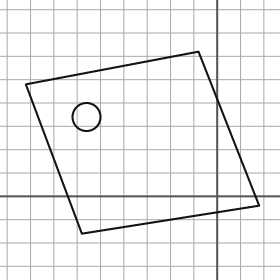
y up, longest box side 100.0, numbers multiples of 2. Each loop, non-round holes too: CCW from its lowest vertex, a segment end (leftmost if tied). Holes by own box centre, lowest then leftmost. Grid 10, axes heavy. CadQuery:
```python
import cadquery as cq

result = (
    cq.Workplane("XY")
    .moveTo(-58.0, -16.0)
    .lineTo(18.0, -4.0)
    .lineTo(-8.0, 62.0)
    .lineTo(-82.0, 48.0)
    .close()
    .moveTo(-56.0, 34.0)
    .circle(6.0)
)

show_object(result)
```